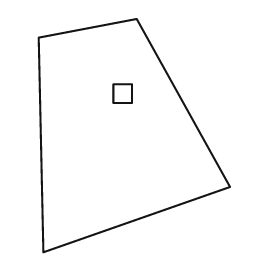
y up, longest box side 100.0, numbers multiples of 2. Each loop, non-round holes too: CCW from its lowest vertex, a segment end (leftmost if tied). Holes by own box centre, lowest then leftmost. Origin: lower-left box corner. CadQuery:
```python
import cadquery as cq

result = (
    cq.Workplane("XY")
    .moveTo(2.0, 0.0)
    .lineTo(82.0, 28.0)
    .lineTo(42.0, 100.0)
    .lineTo(0.0, 92.0)
    .close()
    .moveTo(32.0, 64.0)
    .lineTo(40.0, 64.0)
    .lineTo(40.0, 72.0)
    .lineTo(32.0, 72.0)
    .close()
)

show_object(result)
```